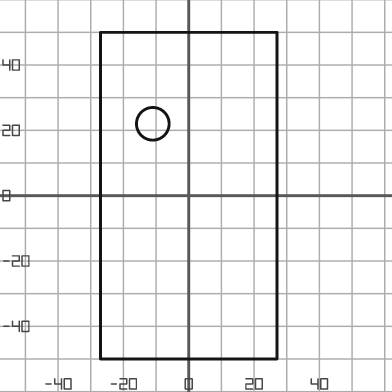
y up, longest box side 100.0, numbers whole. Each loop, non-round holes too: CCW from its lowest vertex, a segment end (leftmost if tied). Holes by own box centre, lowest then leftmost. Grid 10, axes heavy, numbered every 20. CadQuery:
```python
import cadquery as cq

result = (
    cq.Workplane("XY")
    .moveTo(-27.0, -50.0)
    .lineTo(27.0, -50.0)
    .lineTo(27.0, 50.0)
    .lineTo(-27.0, 50.0)
    .close()
    .moveTo(-11.0, 22.0)
    .circle(5.0)
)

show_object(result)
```